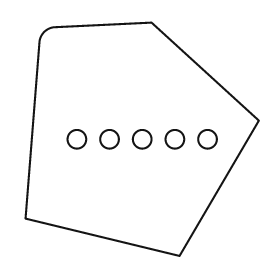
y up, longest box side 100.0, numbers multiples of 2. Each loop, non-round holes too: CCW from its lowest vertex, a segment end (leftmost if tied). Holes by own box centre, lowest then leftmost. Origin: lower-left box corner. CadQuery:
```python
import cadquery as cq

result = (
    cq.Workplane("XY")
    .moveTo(66.0, 0.0)
    .lineTo(100.0, 58.0)
    .lineTo(54.0, 100.0)
    .lineTo(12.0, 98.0)
    .threePointArc((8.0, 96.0), (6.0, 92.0))
    .lineTo(0.0, 16.0)
    .close()
    .moveTo(22.0, 50.0)
    .circle(4.0)
    .moveTo(36.0, 50.0)
    .circle(4.0)
    .moveTo(50.0, 50.0)
    .circle(4.0)
    .moveTo(64.0, 50.0)
    .circle(4.0)
    .moveTo(78.0, 50.0)
    .circle(4.0)
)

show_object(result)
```